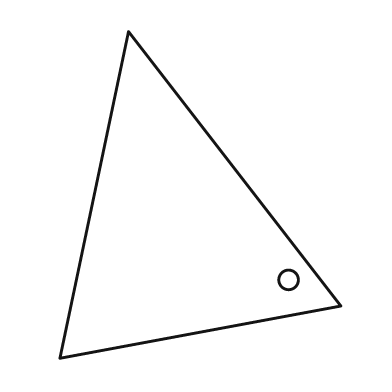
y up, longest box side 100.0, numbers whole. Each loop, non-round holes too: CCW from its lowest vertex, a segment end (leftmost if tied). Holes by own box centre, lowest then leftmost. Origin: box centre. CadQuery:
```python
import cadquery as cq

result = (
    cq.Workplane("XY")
    .moveTo(-43.0, -50.0)
    .lineTo(43.0, -34.0)
    .lineTo(-22.0, 50.0)
    .close()
    .moveTo(27.0, -26.0)
    .circle(3.0)
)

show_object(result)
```